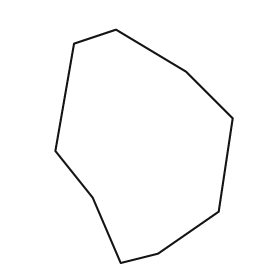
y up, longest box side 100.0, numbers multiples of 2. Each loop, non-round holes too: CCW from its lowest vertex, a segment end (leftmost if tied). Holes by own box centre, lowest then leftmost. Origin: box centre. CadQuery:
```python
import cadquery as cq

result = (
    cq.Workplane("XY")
    .moveTo(-10.0, -50.0)
    .lineTo(6.0, -46.0)
    .lineTo(32.0, -28.0)
    .lineTo(38.0, 12.0)
    .lineTo(18.0, 32.0)
    .lineTo(-12.0, 50.0)
    .lineTo(-30.0, 44.0)
    .lineTo(-38.0, -2.0)
    .lineTo(-22.0, -22.0)
    .close()
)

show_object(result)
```